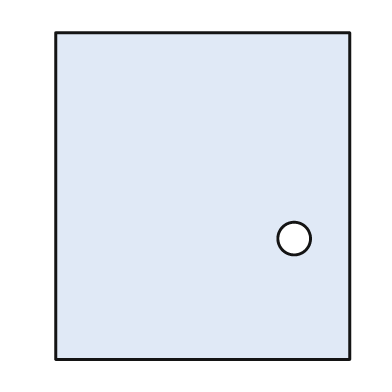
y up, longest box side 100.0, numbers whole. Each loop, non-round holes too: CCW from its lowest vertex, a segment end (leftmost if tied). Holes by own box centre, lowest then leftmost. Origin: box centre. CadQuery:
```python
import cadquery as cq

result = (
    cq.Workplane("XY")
    .moveTo(-45.0, -50.0)
    .lineTo(45.0, -50.0)
    .lineTo(45.0, 50.0)
    .lineTo(-45.0, 50.0)
    .close()
    .moveTo(28.0, -13.0)
    .circle(5.0)
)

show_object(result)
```